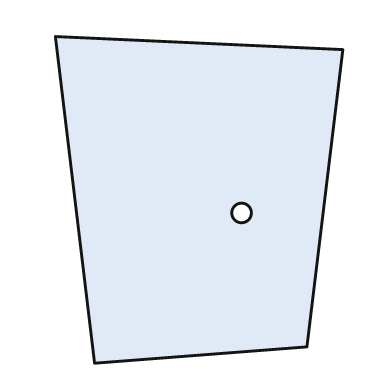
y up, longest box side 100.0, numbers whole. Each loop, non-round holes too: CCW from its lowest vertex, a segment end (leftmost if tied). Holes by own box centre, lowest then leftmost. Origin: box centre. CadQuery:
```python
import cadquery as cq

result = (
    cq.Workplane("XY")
    .moveTo(-32.0, -50.0)
    .lineTo(33.0, -45.0)
    .lineTo(44.0, 46.0)
    .lineTo(-44.0, 50.0)
    .close()
    .moveTo(13.0, -4.0)
    .circle(3.0)
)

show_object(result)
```